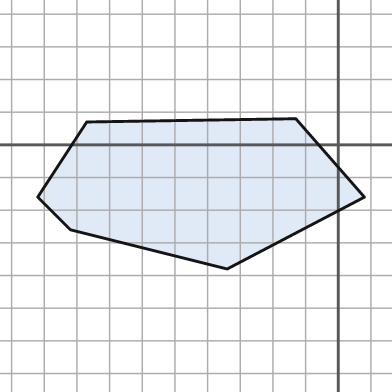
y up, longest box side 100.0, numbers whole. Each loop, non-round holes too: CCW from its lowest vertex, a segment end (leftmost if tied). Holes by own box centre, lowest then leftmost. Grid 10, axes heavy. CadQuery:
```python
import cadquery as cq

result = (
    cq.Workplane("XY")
    .moveTo(-34.0, -38.0)
    .lineTo(8.0, -16.0)
    .lineTo(-13.0, 8.0)
    .lineTo(-77.0, 7.0)
    .lineTo(-92.0, -16.0)
    .lineTo(-82.0, -26.0)
    .close()
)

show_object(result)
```